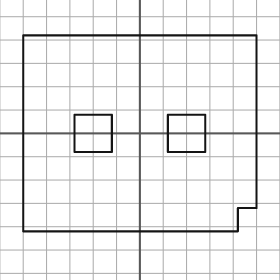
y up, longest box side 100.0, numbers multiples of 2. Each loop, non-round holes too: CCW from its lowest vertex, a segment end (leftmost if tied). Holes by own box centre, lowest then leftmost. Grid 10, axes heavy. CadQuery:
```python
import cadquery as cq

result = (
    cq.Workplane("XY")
    .moveTo(-50.0, -42.0)
    .lineTo(42.0, -42.0)
    .lineTo(42.0, -32.0)
    .lineTo(50.0, -32.0)
    .lineTo(50.0, 42.0)
    .lineTo(-50.0, 42.0)
    .close()
    .moveTo(-28.0, -8.0)
    .lineTo(-12.0, -8.0)
    .lineTo(-12.0, 8.0)
    .lineTo(-28.0, 8.0)
    .close()
    .moveTo(12.0, -8.0)
    .lineTo(28.0, -8.0)
    .lineTo(28.0, 8.0)
    .lineTo(12.0, 8.0)
    .close()
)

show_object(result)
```